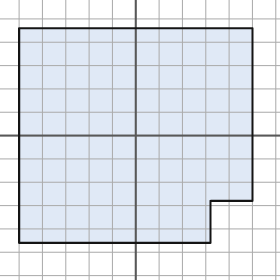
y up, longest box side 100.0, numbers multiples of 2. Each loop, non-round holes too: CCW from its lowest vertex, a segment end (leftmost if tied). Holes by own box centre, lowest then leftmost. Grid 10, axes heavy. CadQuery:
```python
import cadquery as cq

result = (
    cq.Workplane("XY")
    .moveTo(-50.0, -46.0)
    .lineTo(32.0, -46.0)
    .lineTo(32.0, -28.0)
    .lineTo(50.0, -28.0)
    .lineTo(50.0, 46.0)
    .lineTo(-50.0, 46.0)
    .close()
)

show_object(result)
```